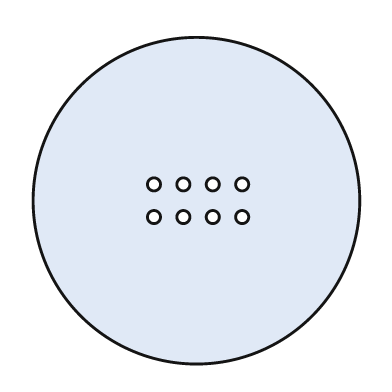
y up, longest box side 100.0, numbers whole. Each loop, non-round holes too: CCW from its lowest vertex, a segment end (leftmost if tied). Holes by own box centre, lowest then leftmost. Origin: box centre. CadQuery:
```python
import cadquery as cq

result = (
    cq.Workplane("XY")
    .moveTo(0.0, 0.0)
    .circle(50.0)
    .moveTo(-13.0, -5.0)
    .circle(2.0)
    .moveTo(-4.0, -5.0)
    .circle(2.0)
    .moveTo(5.0, -5.0)
    .circle(2.0)
    .moveTo(14.0, -5.0)
    .circle(2.0)
    .moveTo(-13.0, 5.0)
    .circle(2.0)
    .moveTo(-4.0, 5.0)
    .circle(2.0)
    .moveTo(5.0, 5.0)
    .circle(2.0)
    .moveTo(14.0, 5.0)
    .circle(2.0)
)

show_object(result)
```